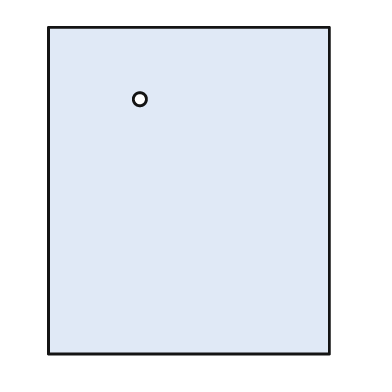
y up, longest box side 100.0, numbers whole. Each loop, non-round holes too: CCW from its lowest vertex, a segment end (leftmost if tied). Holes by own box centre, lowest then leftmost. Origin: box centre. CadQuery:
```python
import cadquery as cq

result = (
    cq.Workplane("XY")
    .moveTo(-43.0, -50.0)
    .lineTo(43.0, -50.0)
    .lineTo(43.0, 50.0)
    .lineTo(-43.0, 50.0)
    .close()
    .moveTo(-15.0, 28.0)
    .circle(2.0)
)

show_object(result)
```